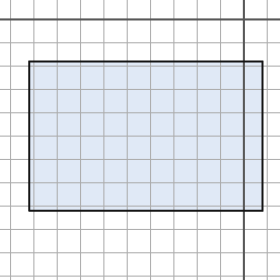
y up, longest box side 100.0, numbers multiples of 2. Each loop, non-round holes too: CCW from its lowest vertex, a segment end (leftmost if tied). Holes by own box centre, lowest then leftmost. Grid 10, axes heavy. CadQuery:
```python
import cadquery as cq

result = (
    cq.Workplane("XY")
    .moveTo(-92.0, -82.0)
    .lineTo(8.0, -82.0)
    .lineTo(8.0, -18.0)
    .lineTo(-92.0, -18.0)
    .close()
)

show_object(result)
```